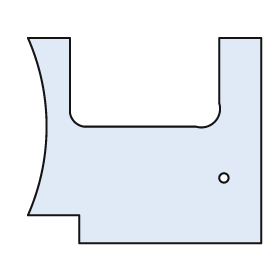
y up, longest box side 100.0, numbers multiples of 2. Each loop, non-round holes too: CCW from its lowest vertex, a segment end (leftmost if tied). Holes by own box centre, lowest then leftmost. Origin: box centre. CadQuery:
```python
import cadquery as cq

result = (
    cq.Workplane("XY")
    .moveTo(-28.0, -44.0)
    .lineTo(50.0, -44.0)
    .lineTo(50.0, 44.0)
    .lineTo(32.0, 44.0)
    .lineTo(32.0, 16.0)
    .threePointArc((30.0, 8.0), (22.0, 6.0))
    .lineTo(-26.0, 6.0)
    .threePointArc((-30.0, 8.0), (-32.0, 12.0))
    .lineTo(-32.0, 44.0)
    .lineTo(-50.0, 44.0)
    .threePointArc((-42.0, 6.0), (-50.0, -32.0))
    .lineTo(-28.0, -32.0)
    .close()
    .moveTo(34.0, -16.0)
    .circle(2.0)
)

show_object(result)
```